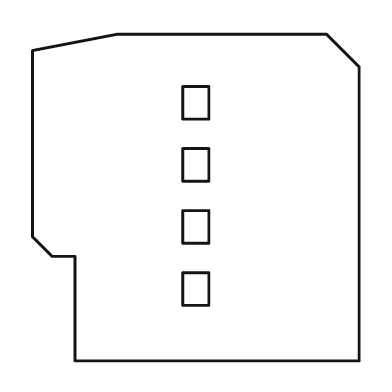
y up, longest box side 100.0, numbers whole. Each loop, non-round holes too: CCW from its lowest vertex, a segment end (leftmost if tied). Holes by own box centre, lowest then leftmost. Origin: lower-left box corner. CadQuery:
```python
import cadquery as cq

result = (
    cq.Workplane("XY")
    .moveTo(13.0, 0.0)
    .lineTo(100.0, 0.0)
    .lineTo(100.0, 90.0)
    .lineTo(90.0, 100.0)
    .lineTo(26.0, 100.0)
    .lineTo(0.0, 95.0)
    .lineTo(0.0, 38.0)
    .lineTo(6.0, 32.0)
    .lineTo(13.0, 32.0)
    .close()
    .moveTo(46.0, 17.0)
    .lineTo(54.0, 17.0)
    .lineTo(54.0, 27.0)
    .lineTo(46.0, 27.0)
    .close()
    .moveTo(46.0, 36.0)
    .lineTo(54.0, 36.0)
    .lineTo(54.0, 46.0)
    .lineTo(46.0, 46.0)
    .close()
    .moveTo(46.0, 55.0)
    .lineTo(54.0, 55.0)
    .lineTo(54.0, 65.0)
    .lineTo(46.0, 65.0)
    .close()
    .moveTo(46.0, 74.0)
    .lineTo(54.0, 74.0)
    .lineTo(54.0, 84.0)
    .lineTo(46.0, 84.0)
    .close()
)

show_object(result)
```